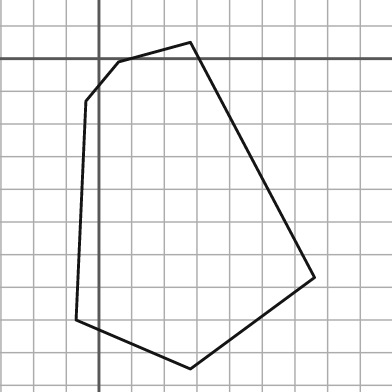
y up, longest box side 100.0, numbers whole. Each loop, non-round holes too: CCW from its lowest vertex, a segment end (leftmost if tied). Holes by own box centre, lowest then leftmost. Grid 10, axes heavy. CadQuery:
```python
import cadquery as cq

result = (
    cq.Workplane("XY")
    .moveTo(28.0, -95.0)
    .lineTo(66.0, -67.0)
    .lineTo(28.0, 5.0)
    .lineTo(6.0, -1.0)
    .lineTo(-4.0, -13.0)
    .lineTo(-7.0, -80.0)
    .close()
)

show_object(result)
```